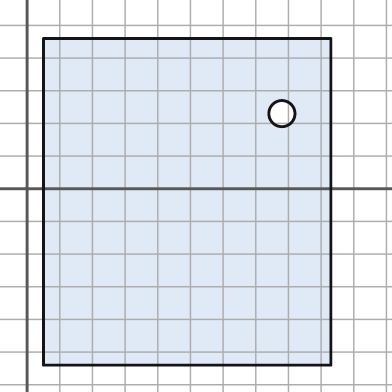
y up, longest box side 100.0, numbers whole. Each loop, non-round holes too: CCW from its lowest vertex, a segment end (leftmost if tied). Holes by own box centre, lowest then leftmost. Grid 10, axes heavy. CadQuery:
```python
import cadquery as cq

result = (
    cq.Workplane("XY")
    .moveTo(5.0, -54.0)
    .lineTo(93.0, -54.0)
    .lineTo(93.0, 46.0)
    .lineTo(5.0, 46.0)
    .close()
    .moveTo(78.0, 23.0)
    .circle(4.0)
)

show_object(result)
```